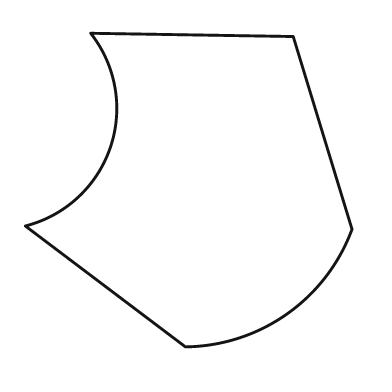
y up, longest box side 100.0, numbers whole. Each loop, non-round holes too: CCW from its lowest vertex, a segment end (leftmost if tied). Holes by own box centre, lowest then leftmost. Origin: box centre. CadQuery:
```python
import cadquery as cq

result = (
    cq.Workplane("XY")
    .moveTo(-1.0, -48.0)
    .threePointArc((30.0, -38.0), (50.0, -12.0))
    .lineTo(32.0, 47.0)
    .lineTo(-30.0, 48.0)
    .threePointArc((-24.0, 13.0), (-50.0, -11.0))
    .close()
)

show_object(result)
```